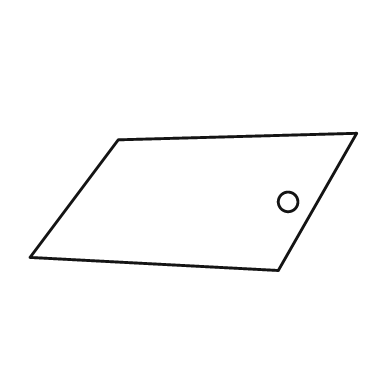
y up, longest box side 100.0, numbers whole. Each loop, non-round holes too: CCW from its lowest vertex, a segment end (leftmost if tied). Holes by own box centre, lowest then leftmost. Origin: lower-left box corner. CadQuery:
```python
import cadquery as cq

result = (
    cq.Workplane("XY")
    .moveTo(76.0, 0.0)
    .lineTo(100.0, 42.0)
    .lineTo(27.0, 40.0)
    .lineTo(0.0, 4.0)
    .close()
    .moveTo(79.0, 21.0)
    .circle(3.0)
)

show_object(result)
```